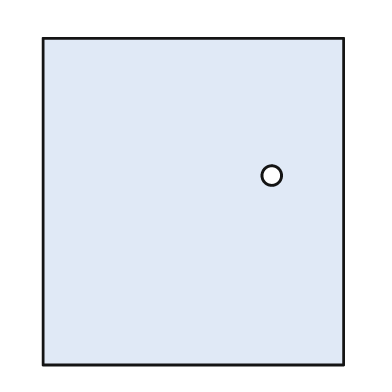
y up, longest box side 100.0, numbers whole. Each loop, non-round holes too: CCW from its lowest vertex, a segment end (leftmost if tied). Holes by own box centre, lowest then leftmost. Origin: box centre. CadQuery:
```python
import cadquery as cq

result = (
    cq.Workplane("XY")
    .moveTo(-46.0, -50.0)
    .lineTo(46.0, -50.0)
    .lineTo(46.0, 50.0)
    .lineTo(-46.0, 50.0)
    .close()
    .moveTo(24.0, 8.0)
    .circle(3.0)
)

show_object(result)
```